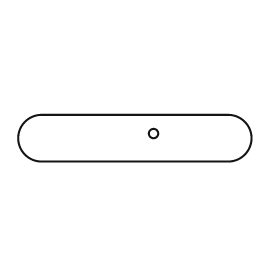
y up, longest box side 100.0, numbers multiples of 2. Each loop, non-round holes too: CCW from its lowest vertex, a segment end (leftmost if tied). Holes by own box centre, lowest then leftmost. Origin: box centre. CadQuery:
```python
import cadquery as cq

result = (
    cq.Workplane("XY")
    .moveTo(-40.0, -10.0)
    .lineTo(40.0, -10.0)
    .threePointArc((50.0, 0.0), (40.0, 10.0))
    .lineTo(-40.0, 10.0)
    .threePointArc((-50.0, 0.0), (-40.0, -10.0))
    .close()
    .moveTo(8.0, 2.0)
    .circle(2.0)
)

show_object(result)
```